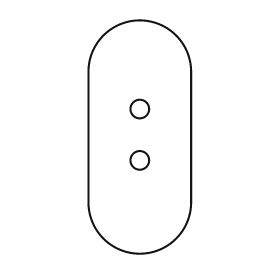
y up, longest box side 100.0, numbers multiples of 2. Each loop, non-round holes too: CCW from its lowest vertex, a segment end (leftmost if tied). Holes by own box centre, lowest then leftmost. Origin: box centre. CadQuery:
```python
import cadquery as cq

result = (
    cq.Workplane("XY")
    .moveTo(-22.0, -28.0)
    .threePointArc((0.0, -50.0), (22.0, -28.0))
    .lineTo(22.0, 28.0)
    .threePointArc((0.0, 50.0), (-22.0, 28.0))
    .close()
    .moveTo(0.0, -10.0)
    .circle(4.0)
    .moveTo(0.0, 12.0)
    .circle(4.0)
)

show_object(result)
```